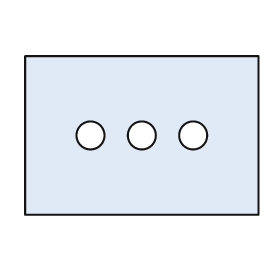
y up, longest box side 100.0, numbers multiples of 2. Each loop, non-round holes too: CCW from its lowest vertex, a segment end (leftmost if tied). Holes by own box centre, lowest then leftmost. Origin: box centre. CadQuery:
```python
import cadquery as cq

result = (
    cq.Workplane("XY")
    .moveTo(-50.0, -34.0)
    .lineTo(50.0, -34.0)
    .lineTo(50.0, 34.0)
    .lineTo(-50.0, 34.0)
    .close()
    .moveTo(-22.0, 0.0)
    .circle(6.0)
    .moveTo(0.0, 0.0)
    .circle(6.0)
    .moveTo(22.0, 0.0)
    .circle(6.0)
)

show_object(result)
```